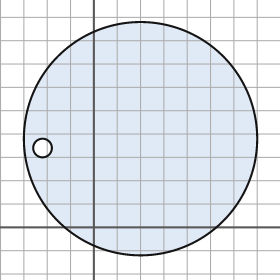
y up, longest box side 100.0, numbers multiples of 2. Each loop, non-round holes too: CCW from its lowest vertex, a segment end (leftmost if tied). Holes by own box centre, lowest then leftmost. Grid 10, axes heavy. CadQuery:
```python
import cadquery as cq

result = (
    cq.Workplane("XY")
    .moveTo(20.0, 38.0)
    .circle(50.0)
    .moveTo(-22.0, 34.0)
    .circle(4.0)
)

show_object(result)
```